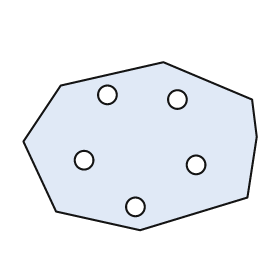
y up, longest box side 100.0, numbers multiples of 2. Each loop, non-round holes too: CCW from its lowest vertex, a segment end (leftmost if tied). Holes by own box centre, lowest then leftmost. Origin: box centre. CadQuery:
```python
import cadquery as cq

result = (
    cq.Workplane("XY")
    .moveTo(0.0, -36.0)
    .lineTo(46.0, -22.0)
    .lineTo(50.0, 4.0)
    .lineTo(48.0, 20.0)
    .lineTo(10.0, 36.0)
    .lineTo(-34.0, 26.0)
    .lineTo(-50.0, 2.0)
    .lineTo(-36.0, -28.0)
    .close()
    .moveTo(-2.0, -26.0)
    .circle(4.0)
    .moveTo(24.0, -8.0)
    .circle(4.0)
    .moveTo(-24.0, -6.0)
    .circle(4.0)
    .moveTo(16.0, 20.0)
    .circle(4.0)
    .moveTo(-14.0, 22.0)
    .circle(4.0)
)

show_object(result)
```